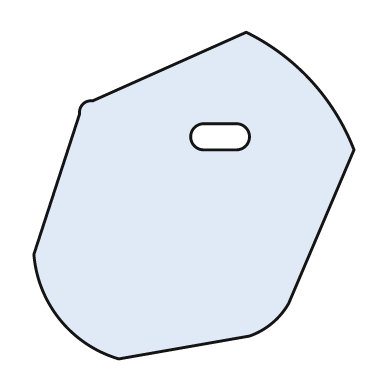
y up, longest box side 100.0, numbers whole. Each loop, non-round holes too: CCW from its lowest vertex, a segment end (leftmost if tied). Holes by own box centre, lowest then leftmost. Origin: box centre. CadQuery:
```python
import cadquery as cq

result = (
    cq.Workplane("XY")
    .moveTo(-23.0, -50.0)
    .lineTo(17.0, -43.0)
    .threePointArc((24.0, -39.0), (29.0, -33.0))
    .lineTo(49.0, 14.0)
    .threePointArc((36.0, 35.0), (16.0, 50.0))
    .lineTo(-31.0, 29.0)
    .threePointArc((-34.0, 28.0), (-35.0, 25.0))
    .lineTo(-49.0, -18.0)
    .threePointArc((-41.0, -38.0), (-23.0, -50.0))
    .close()
    .moveTo(3.0, 14.0)
    .lineTo(13.0, 14.0)
    .threePointArc((17.0, 18.0), (13.0, 22.0))
    .lineTo(3.0, 22.0)
    .threePointArc((-1.0, 18.0), (3.0, 14.0))
    .close()
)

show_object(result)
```